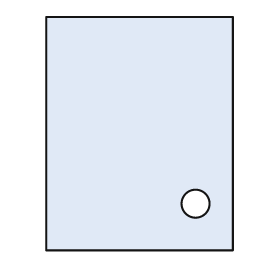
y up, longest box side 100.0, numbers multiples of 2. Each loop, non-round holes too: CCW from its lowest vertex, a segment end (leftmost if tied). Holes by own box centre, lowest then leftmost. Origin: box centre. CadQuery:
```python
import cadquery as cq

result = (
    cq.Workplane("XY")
    .moveTo(-40.0, -50.0)
    .lineTo(40.0, -50.0)
    .lineTo(40.0, 50.0)
    .lineTo(-40.0, 50.0)
    .close()
    .moveTo(24.0, -30.0)
    .circle(6.0)
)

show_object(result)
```